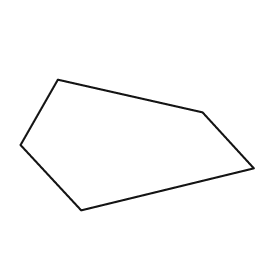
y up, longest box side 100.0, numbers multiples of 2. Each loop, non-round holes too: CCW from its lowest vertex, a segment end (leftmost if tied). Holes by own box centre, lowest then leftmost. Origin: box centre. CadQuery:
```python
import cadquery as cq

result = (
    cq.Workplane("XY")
    .moveTo(-24.0, -28.0)
    .lineTo(50.0, -10.0)
    .lineTo(28.0, 14.0)
    .lineTo(-34.0, 28.0)
    .lineTo(-50.0, 0.0)
    .close()
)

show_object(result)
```